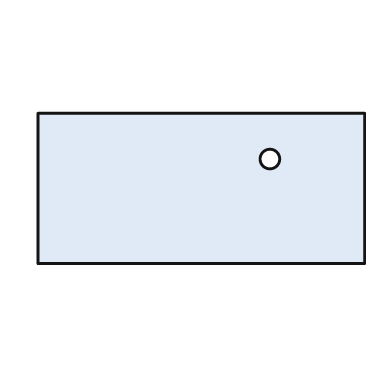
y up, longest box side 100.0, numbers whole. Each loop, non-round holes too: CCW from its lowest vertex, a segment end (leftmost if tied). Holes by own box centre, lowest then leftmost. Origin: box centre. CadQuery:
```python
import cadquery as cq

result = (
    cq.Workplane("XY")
    .moveTo(-50.0, -23.0)
    .lineTo(50.0, -23.0)
    .lineTo(50.0, 23.0)
    .lineTo(-50.0, 23.0)
    .close()
    .moveTo(21.0, 9.0)
    .circle(3.0)
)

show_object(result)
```